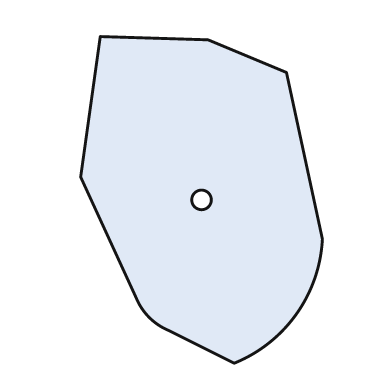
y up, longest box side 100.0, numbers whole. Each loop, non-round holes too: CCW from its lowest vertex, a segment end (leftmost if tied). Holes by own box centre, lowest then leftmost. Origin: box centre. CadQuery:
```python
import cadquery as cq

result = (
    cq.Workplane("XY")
    .moveTo(10.0, -50.0)
    .threePointArc((29.0, -35.0), (37.0, -12.0))
    .lineTo(26.0, 39.0)
    .lineTo(2.0, 49.0)
    .lineTo(-31.0, 50.0)
    .lineTo(-37.0, 7.0)
    .lineTo(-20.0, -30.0)
    .threePointArc((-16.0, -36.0), (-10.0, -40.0))
    .close()
    .moveTo(0.0, 0.0)
    .circle(3.0)
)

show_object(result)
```